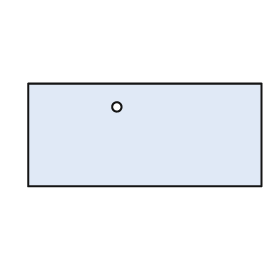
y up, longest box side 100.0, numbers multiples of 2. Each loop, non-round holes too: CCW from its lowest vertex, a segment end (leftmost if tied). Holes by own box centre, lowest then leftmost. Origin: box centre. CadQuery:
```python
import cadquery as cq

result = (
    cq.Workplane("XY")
    .moveTo(-50.0, -22.0)
    .lineTo(50.0, -22.0)
    .lineTo(50.0, 22.0)
    .lineTo(-50.0, 22.0)
    .close()
    .moveTo(-12.0, 12.0)
    .circle(2.0)
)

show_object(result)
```